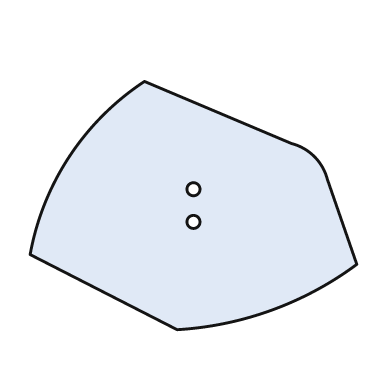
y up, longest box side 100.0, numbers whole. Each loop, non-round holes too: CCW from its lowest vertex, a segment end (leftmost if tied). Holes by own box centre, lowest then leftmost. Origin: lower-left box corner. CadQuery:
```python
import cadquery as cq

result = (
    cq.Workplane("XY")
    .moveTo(45.0, 0.0)
    .threePointArc((74.0, 6.0), (100.0, 20.0))
    .lineTo(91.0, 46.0)
    .threePointArc((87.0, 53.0), (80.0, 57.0))
    .lineTo(35.0, 76.0)
    .threePointArc((12.0, 53.0), (0.0, 23.0))
    .close()
    .moveTo(50.0, 33.0)
    .circle(2.0)
    .moveTo(50.0, 43.0)
    .circle(2.0)
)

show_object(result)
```